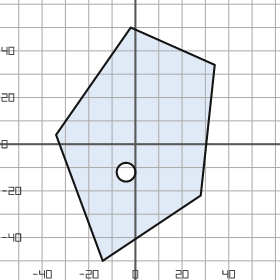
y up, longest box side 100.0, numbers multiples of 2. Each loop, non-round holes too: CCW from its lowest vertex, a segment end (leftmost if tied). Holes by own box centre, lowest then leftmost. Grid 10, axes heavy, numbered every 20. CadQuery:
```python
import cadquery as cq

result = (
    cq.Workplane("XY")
    .moveTo(-14.0, -50.0)
    .lineTo(28.0, -22.0)
    .lineTo(34.0, 34.0)
    .lineTo(-2.0, 50.0)
    .lineTo(-34.0, 4.0)
    .close()
    .moveTo(-4.0, -12.0)
    .circle(4.0)
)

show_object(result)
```